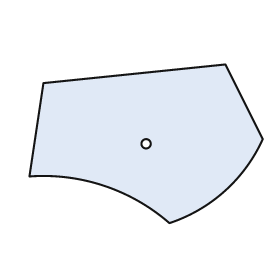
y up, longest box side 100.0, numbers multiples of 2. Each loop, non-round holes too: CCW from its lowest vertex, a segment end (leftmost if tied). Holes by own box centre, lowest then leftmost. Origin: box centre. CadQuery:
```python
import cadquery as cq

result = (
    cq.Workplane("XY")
    .moveTo(10.0, -34.0)
    .threePointArc((34.0, -20.0), (50.0, 2.0))
    .lineTo(34.0, 34.0)
    .lineTo(-44.0, 26.0)
    .lineTo(-50.0, -14.0)
    .threePointArc((-18.0, -18.0), (10.0, -34.0))
    .close()
    .moveTo(0.0, 0.0)
    .circle(2.0)
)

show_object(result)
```